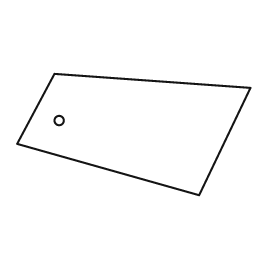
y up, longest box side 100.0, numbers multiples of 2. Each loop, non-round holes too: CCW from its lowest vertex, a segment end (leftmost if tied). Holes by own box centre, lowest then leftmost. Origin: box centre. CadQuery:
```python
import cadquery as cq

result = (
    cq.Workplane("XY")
    .moveTo(28.0, -26.0)
    .lineTo(50.0, 20.0)
    .lineTo(-34.0, 26.0)
    .lineTo(-50.0, -4.0)
    .close()
    .moveTo(-32.0, 6.0)
    .circle(2.0)
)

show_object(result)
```